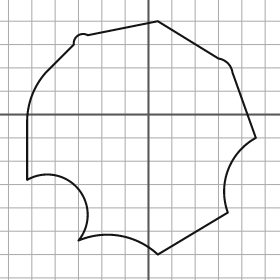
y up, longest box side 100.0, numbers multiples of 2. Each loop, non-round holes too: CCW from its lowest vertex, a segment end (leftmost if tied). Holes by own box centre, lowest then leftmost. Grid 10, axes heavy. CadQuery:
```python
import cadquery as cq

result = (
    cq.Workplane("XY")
    .moveTo(4.0, -60.0)
    .lineTo(34.0, -42.0)
    .threePointArc((34.0, -24.0), (46.0, -10.0))
    .lineTo(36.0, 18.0)
    .threePointArc((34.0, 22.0), (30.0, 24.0))
    .lineTo(4.0, 40.0)
    .lineTo(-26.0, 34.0)
    .threePointArc((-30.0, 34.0), (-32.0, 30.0))
    .lineTo(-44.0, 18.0)
    .threePointArc((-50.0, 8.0), (-52.0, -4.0))
    .lineTo(-52.0, -28.0)
    .threePointArc((-30.0, -32.0), (-30.0, -54.0))
    .threePointArc((-12.0, -52.0), (4.0, -60.0))
    .close()
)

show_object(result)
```